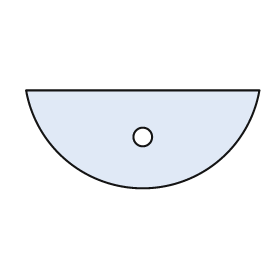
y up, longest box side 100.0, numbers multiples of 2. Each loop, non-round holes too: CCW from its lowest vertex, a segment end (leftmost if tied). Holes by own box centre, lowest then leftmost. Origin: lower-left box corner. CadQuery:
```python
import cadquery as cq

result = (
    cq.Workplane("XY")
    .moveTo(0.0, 42.0)
    .threePointArc((50.0, 0.0), (100.0, 42.0))
    .close()
    .moveTo(50.0, 22.0)
    .circle(4.0)
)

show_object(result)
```